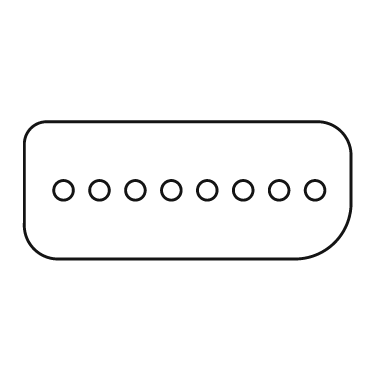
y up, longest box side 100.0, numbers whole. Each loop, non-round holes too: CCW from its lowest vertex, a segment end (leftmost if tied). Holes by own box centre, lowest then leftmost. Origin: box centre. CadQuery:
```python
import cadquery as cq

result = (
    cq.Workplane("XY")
    .moveTo(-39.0, -21.0)
    .lineTo(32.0, -21.0)
    .threePointArc((45.0, -16.0), (50.0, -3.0))
    .lineTo(50.0, 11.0)
    .threePointArc((47.0, 18.0), (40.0, 21.0))
    .lineTo(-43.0, 21.0)
    .threePointArc((-48.0, 19.0), (-50.0, 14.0))
    .lineTo(-50.0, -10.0)
    .threePointArc((-47.0, -18.0), (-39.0, -21.0))
    .close()
    .moveTo(-38.0, 0.0)
    .circle(3.0)
    .moveTo(-27.0, 0.0)
    .circle(3.0)
    .moveTo(-16.0, 0.0)
    .circle(3.0)
    .moveTo(-5.0, 0.0)
    .circle(3.0)
    .moveTo(6.0, 0.0)
    .circle(3.0)
    .moveTo(17.0, 0.0)
    .circle(3.0)
    .moveTo(28.0, 0.0)
    .circle(3.0)
    .moveTo(39.0, 0.0)
    .circle(3.0)
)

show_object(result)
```